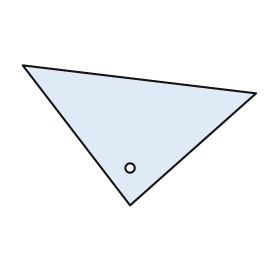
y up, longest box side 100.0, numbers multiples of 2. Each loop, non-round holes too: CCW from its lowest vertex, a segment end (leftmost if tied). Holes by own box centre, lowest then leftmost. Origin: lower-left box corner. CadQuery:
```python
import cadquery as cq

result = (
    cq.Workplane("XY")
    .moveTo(46.0, 0.0)
    .lineTo(100.0, 48.0)
    .lineTo(0.0, 60.0)
    .close()
    .moveTo(46.0, 16.0)
    .circle(2.0)
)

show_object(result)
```